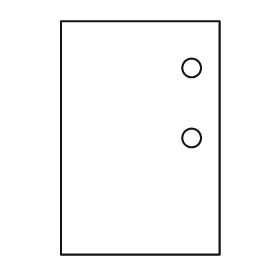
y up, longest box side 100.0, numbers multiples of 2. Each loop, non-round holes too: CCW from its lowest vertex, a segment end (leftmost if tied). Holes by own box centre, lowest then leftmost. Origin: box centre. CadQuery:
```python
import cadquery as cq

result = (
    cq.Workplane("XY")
    .moveTo(-34.0, -50.0)
    .lineTo(34.0, -50.0)
    .lineTo(34.0, 50.0)
    .lineTo(-34.0, 50.0)
    .close()
    .moveTo(22.0, 0.0)
    .circle(4.0)
    .moveTo(22.0, 30.0)
    .circle(4.0)
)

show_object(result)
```